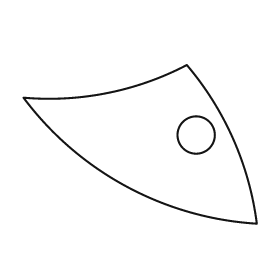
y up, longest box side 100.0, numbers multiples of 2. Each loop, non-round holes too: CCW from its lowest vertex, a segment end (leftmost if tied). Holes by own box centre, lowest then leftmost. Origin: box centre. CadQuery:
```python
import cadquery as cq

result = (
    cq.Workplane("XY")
    .moveTo(50.0, -34.0)
    .threePointArc((40.0, 2.0), (20.0, 34.0))
    .threePointArc((-14.0, 22.0), (-50.0, 20.0))
    .threePointArc((-6.0, -18.0), (50.0, -34.0))
    .close()
    .moveTo(24.0, 4.0)
    .circle(8.0)
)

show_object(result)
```